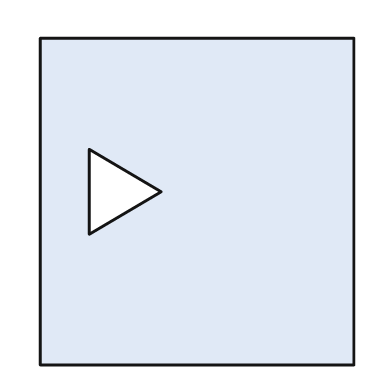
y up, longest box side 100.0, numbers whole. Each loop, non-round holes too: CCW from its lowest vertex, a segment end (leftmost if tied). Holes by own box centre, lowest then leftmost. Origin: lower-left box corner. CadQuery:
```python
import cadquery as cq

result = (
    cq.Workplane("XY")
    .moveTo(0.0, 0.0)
    .lineTo(96.0, 0.0)
    .lineTo(96.0, 100.0)
    .lineTo(0.0, 100.0)
    .close()
    .moveTo(15.0, 40.0)
    .lineTo(37.0, 53.0)
    .lineTo(15.0, 66.0)
    .close()
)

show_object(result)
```